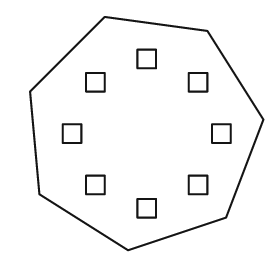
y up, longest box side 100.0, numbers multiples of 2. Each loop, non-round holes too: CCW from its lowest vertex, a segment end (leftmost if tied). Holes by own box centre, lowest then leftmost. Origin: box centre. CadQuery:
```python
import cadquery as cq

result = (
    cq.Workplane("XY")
    .moveTo(-8.0, -50.0)
    .lineTo(34.0, -36.0)
    .lineTo(50.0, 6.0)
    .lineTo(26.0, 44.0)
    .lineTo(-18.0, 50.0)
    .lineTo(-50.0, 18.0)
    .lineTo(-46.0, -26.0)
    .close()
    .moveTo(-4.0, -36.0)
    .lineTo(4.0, -36.0)
    .lineTo(4.0, -28.0)
    .lineTo(-4.0, -28.0)
    .close()
    .moveTo(-26.0, -26.0)
    .lineTo(-18.0, -26.0)
    .lineTo(-18.0, -18.0)
    .lineTo(-26.0, -18.0)
    .close()
    .moveTo(18.0, -26.0)
    .lineTo(26.0, -26.0)
    .lineTo(26.0, -18.0)
    .lineTo(18.0, -18.0)
    .close()
    .moveTo(-36.0, -4.0)
    .lineTo(-28.0, -4.0)
    .lineTo(-28.0, 4.0)
    .lineTo(-36.0, 4.0)
    .close()
    .moveTo(28.0, -4.0)
    .lineTo(36.0, -4.0)
    .lineTo(36.0, 4.0)
    .lineTo(28.0, 4.0)
    .close()
    .moveTo(-26.0, 18.0)
    .lineTo(-18.0, 18.0)
    .lineTo(-18.0, 26.0)
    .lineTo(-26.0, 26.0)
    .close()
    .moveTo(18.0, 18.0)
    .lineTo(26.0, 18.0)
    .lineTo(26.0, 26.0)
    .lineTo(18.0, 26.0)
    .close()
    .moveTo(-4.0, 28.0)
    .lineTo(4.0, 28.0)
    .lineTo(4.0, 36.0)
    .lineTo(-4.0, 36.0)
    .close()
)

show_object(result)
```